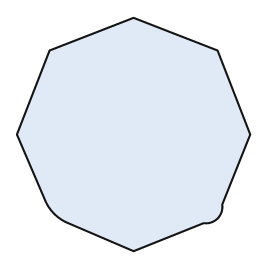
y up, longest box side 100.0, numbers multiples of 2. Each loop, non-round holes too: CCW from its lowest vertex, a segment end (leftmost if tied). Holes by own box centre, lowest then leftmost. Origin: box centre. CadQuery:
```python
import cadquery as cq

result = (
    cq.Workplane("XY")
    .moveTo(0.0, -50.0)
    .lineTo(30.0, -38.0)
    .threePointArc((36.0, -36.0), (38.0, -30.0))
    .lineTo(50.0, 0.0)
    .lineTo(36.0, 36.0)
    .lineTo(0.0, 50.0)
    .lineTo(-36.0, 36.0)
    .lineTo(-50.0, 0.0)
    .lineTo(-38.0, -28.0)
    .threePointArc((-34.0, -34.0), (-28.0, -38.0))
    .close()
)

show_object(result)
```